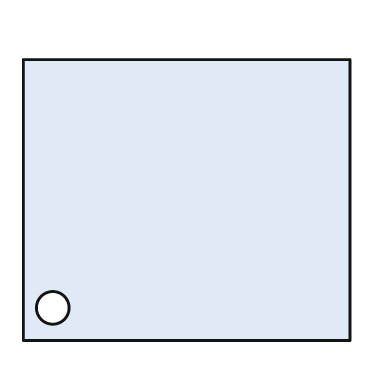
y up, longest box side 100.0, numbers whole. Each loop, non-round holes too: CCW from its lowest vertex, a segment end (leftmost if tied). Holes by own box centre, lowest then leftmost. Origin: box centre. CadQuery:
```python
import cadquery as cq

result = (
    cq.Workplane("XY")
    .moveTo(-50.0, -43.0)
    .lineTo(50.0, -43.0)
    .lineTo(50.0, 43.0)
    .lineTo(-50.0, 43.0)
    .close()
    .moveTo(-41.0, -33.0)
    .circle(5.0)
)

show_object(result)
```